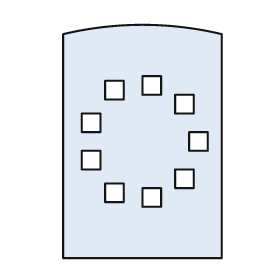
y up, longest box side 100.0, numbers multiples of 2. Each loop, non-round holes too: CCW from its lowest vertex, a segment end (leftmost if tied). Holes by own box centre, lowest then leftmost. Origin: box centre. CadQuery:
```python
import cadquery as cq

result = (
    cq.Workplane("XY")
    .moveTo(-34.0, -50.0)
    .lineTo(34.0, -50.0)
    .lineTo(34.0, 46.0)
    .threePointArc((0.0, 50.0), (-34.0, 46.0))
    .close()
    .moveTo(0.0, -28.0)
    .lineTo(8.0, -28.0)
    .lineTo(8.0, -20.0)
    .lineTo(0.0, -20.0)
    .close()
    .moveTo(-16.0, -26.0)
    .lineTo(-8.0, -26.0)
    .lineTo(-8.0, -18.0)
    .lineTo(-16.0, -18.0)
    .close()
    .moveTo(14.0, -20.0)
    .lineTo(22.0, -20.0)
    .lineTo(22.0, -12.0)
    .lineTo(14.0, -12.0)
    .close()
    .moveTo(-26.0, -12.0)
    .lineTo(-18.0, -12.0)
    .lineTo(-18.0, -4.0)
    .lineTo(-26.0, -4.0)
    .close()
    .moveTo(20.0, -4.0)
    .lineTo(28.0, -4.0)
    .lineTo(28.0, 4.0)
    .lineTo(20.0, 4.0)
    .close()
    .moveTo(-26.0, 4.0)
    .lineTo(-18.0, 4.0)
    .lineTo(-18.0, 12.0)
    .lineTo(-26.0, 12.0)
    .close()
    .moveTo(14.0, 12.0)
    .lineTo(22.0, 12.0)
    .lineTo(22.0, 20.0)
    .lineTo(14.0, 20.0)
    .close()
    .moveTo(-16.0, 18.0)
    .lineTo(-8.0, 18.0)
    .lineTo(-8.0, 26.0)
    .lineTo(-16.0, 26.0)
    .close()
    .moveTo(0.0, 20.0)
    .lineTo(8.0, 20.0)
    .lineTo(8.0, 28.0)
    .lineTo(0.0, 28.0)
    .close()
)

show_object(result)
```